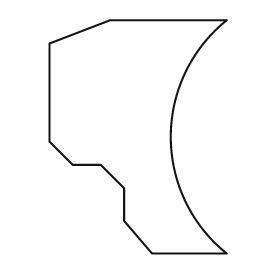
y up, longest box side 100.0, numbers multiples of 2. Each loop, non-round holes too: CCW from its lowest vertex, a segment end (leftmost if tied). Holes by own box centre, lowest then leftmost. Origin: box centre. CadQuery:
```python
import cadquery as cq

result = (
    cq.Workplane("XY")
    .moveTo(6.0, -50.0)
    .lineTo(38.0, -50.0)
    .threePointArc((14.0, 0.0), (38.0, 50.0))
    .lineTo(-12.0, 50.0)
    .lineTo(-38.0, 40.0)
    .lineTo(-38.0, -2.0)
    .lineTo(-28.0, -12.0)
    .lineTo(-16.0, -12.0)
    .lineTo(-6.0, -22.0)
    .lineTo(-6.0, -36.0)
    .close()
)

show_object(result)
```